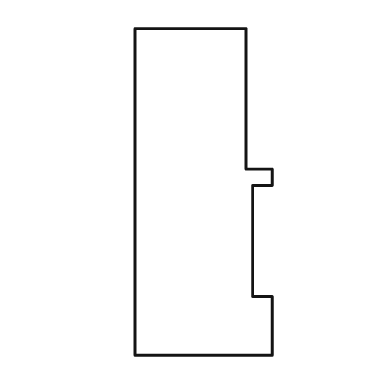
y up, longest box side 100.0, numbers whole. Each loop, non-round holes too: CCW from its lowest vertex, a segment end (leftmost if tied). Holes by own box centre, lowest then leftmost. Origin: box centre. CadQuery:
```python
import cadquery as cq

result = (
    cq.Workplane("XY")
    .moveTo(-21.0, -50.0)
    .lineTo(21.0, -50.0)
    .lineTo(21.0, -32.0)
    .lineTo(15.0, -32.0)
    .lineTo(15.0, 2.0)
    .lineTo(21.0, 2.0)
    .lineTo(21.0, 7.0)
    .lineTo(13.0, 7.0)
    .lineTo(13.0, 50.0)
    .lineTo(-21.0, 50.0)
    .close()
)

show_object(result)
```